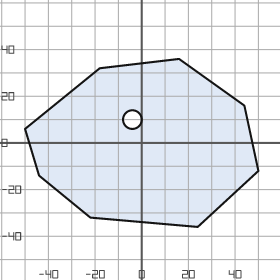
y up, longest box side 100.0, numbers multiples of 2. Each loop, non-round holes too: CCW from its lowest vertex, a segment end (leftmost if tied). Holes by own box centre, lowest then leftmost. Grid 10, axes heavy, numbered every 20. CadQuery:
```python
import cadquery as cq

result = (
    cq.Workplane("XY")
    .moveTo(24.0, -36.0)
    .lineTo(50.0, -12.0)
    .lineTo(44.0, 16.0)
    .lineTo(16.0, 36.0)
    .lineTo(-18.0, 32.0)
    .lineTo(-50.0, 6.0)
    .lineTo(-44.0, -14.0)
    .lineTo(-22.0, -32.0)
    .close()
    .moveTo(-4.0, 10.0)
    .circle(4.0)
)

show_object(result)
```